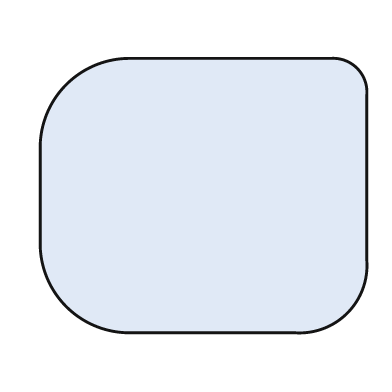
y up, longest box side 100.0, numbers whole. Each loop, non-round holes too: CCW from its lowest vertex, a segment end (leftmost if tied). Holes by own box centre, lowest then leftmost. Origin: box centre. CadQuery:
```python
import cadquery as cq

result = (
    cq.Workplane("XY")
    .moveTo(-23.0, -42.0)
    .lineTo(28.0, -42.0)
    .threePointArc((44.0, -36.0), (50.0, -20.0))
    .lineTo(50.0, 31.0)
    .threePointArc((47.0, 39.0), (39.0, 42.0))
    .lineTo(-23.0, 42.0)
    .threePointArc((-42.0, 34.0), (-50.0, 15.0))
    .lineTo(-50.0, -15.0)
    .threePointArc((-42.0, -34.0), (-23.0, -42.0))
    .close()
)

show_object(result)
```